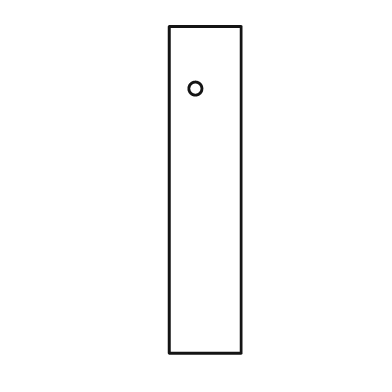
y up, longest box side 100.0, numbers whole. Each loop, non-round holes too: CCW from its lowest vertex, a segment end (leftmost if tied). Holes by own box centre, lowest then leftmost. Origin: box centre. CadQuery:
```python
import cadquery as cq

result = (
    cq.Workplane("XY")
    .moveTo(-11.0, -50.0)
    .lineTo(11.0, -50.0)
    .lineTo(11.0, 50.0)
    .lineTo(-11.0, 50.0)
    .close()
    .moveTo(-3.0, 31.0)
    .circle(2.0)
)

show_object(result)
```